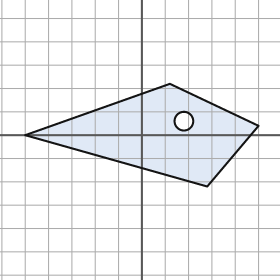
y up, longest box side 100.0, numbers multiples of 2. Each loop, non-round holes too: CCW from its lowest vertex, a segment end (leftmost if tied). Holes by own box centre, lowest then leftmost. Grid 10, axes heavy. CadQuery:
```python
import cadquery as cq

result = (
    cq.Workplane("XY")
    .moveTo(28.0, -22.0)
    .lineTo(50.0, 4.0)
    .lineTo(12.0, 22.0)
    .lineTo(-50.0, 0.0)
    .close()
    .moveTo(18.0, 6.0)
    .circle(4.0)
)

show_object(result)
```